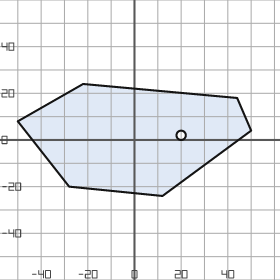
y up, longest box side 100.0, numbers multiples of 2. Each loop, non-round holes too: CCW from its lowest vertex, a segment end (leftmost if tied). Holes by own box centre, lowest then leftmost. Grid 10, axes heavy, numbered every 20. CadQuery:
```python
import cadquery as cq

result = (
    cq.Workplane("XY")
    .moveTo(12.0, -24.0)
    .lineTo(50.0, 4.0)
    .lineTo(44.0, 18.0)
    .lineTo(-22.0, 24.0)
    .lineTo(-50.0, 8.0)
    .lineTo(-28.0, -20.0)
    .close()
    .moveTo(20.0, 2.0)
    .circle(2.0)
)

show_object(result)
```